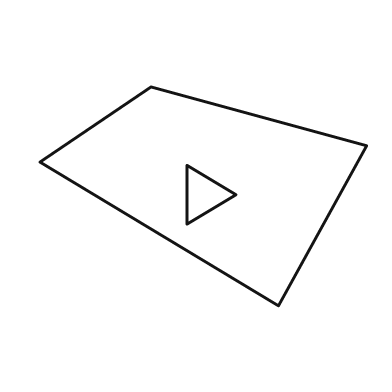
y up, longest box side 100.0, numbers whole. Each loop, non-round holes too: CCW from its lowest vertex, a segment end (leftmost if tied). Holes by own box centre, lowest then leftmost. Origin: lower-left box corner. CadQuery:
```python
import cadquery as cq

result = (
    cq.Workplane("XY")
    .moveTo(73.0, 0.0)
    .lineTo(100.0, 49.0)
    .lineTo(34.0, 67.0)
    .lineTo(0.0, 44.0)
    .close()
    .moveTo(45.0, 25.0)
    .lineTo(60.0, 34.0)
    .lineTo(45.0, 43.0)
    .close()
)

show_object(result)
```